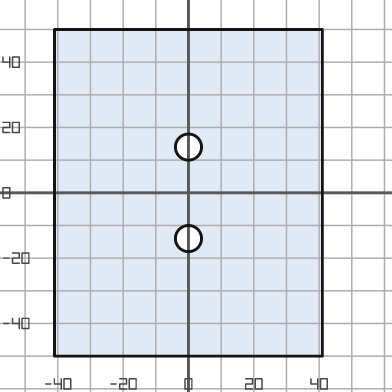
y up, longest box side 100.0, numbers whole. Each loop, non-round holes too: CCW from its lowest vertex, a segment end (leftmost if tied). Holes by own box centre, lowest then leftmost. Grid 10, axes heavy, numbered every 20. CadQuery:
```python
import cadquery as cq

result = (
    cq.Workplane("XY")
    .moveTo(-41.0, -50.0)
    .lineTo(41.0, -50.0)
    .lineTo(41.0, 50.0)
    .lineTo(-41.0, 50.0)
    .close()
    .moveTo(0.0, -14.0)
    .circle(4.0)
    .moveTo(0.0, 14.0)
    .circle(4.0)
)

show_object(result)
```